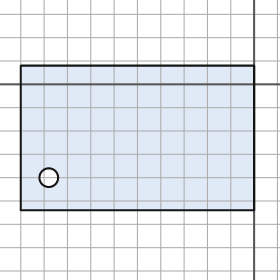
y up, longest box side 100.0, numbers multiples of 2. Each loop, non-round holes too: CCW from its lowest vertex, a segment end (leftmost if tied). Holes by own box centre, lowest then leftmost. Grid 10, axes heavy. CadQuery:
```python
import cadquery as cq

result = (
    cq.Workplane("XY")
    .moveTo(-100.0, -54.0)
    .lineTo(0.0, -54.0)
    .lineTo(0.0, 8.0)
    .lineTo(-100.0, 8.0)
    .close()
    .moveTo(-88.0, -40.0)
    .circle(4.0)
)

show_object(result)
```